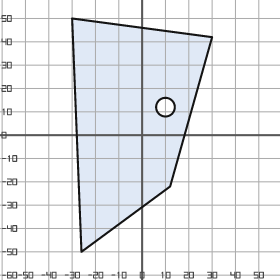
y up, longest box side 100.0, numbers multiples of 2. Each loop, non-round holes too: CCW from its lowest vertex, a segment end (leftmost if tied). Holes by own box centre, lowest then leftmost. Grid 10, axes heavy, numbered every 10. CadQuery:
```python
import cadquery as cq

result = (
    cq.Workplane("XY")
    .moveTo(-26.0, -50.0)
    .lineTo(12.0, -22.0)
    .lineTo(30.0, 42.0)
    .lineTo(-30.0, 50.0)
    .close()
    .moveTo(10.0, 12.0)
    .circle(4.0)
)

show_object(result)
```